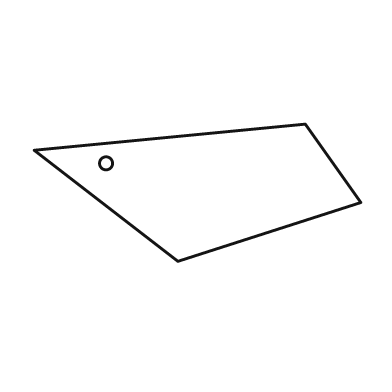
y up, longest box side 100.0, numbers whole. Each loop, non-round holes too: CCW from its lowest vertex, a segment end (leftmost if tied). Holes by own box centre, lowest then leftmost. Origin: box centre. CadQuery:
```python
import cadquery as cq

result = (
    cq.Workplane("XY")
    .moveTo(-6.0, -21.0)
    .lineTo(50.0, -3.0)
    .lineTo(33.0, 21.0)
    .lineTo(-50.0, 13.0)
    .close()
    .moveTo(-28.0, 9.0)
    .circle(2.0)
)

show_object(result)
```